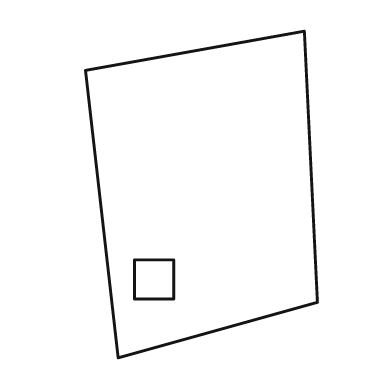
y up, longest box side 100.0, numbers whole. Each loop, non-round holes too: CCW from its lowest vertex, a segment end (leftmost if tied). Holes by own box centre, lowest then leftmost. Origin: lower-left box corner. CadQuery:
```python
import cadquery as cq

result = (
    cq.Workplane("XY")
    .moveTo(10.0, 0.0)
    .lineTo(71.0, 17.0)
    .lineTo(67.0, 100.0)
    .lineTo(0.0, 88.0)
    .close()
    .moveTo(15.0, 18.0)
    .lineTo(27.0, 18.0)
    .lineTo(27.0, 30.0)
    .lineTo(15.0, 30.0)
    .close()
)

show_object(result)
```